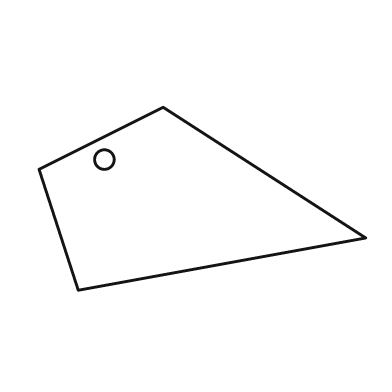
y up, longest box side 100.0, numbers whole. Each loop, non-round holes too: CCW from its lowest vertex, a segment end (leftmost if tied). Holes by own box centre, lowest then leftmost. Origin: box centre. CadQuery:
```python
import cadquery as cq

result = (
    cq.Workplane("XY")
    .moveTo(-38.0, -28.0)
    .lineTo(50.0, -12.0)
    .lineTo(-12.0, 28.0)
    .lineTo(-50.0, 9.0)
    .close()
    .moveTo(-30.0, 12.0)
    .circle(3.0)
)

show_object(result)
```